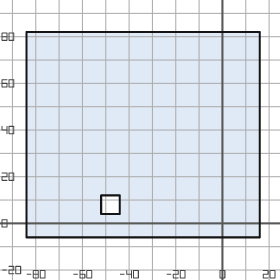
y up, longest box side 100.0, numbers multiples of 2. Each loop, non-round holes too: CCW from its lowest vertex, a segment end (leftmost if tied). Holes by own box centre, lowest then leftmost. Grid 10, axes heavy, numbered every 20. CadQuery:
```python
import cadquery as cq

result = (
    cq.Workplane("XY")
    .moveTo(-84.0, -6.0)
    .lineTo(16.0, -6.0)
    .lineTo(16.0, 82.0)
    .lineTo(-84.0, 82.0)
    .close()
    .moveTo(-52.0, 4.0)
    .lineTo(-44.0, 4.0)
    .lineTo(-44.0, 12.0)
    .lineTo(-52.0, 12.0)
    .close()
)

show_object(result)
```